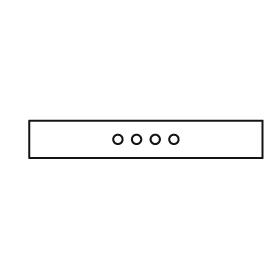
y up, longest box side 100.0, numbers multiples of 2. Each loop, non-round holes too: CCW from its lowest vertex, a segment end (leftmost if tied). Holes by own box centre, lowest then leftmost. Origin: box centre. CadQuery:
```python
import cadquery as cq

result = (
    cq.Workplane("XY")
    .moveTo(-50.0, -8.0)
    .lineTo(50.0, -8.0)
    .lineTo(50.0, 8.0)
    .lineTo(-50.0, 8.0)
    .close()
    .moveTo(-12.0, 0.0)
    .circle(2.0)
    .moveTo(-4.0, 0.0)
    .circle(2.0)
    .moveTo(4.0, 0.0)
    .circle(2.0)
    .moveTo(12.0, 0.0)
    .circle(2.0)
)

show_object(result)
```